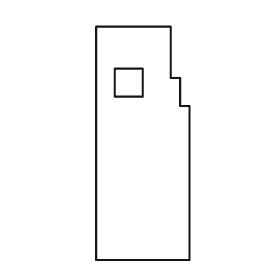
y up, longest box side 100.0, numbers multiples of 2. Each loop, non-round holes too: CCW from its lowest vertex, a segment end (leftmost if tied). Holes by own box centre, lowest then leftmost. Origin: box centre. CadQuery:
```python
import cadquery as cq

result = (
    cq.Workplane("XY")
    .moveTo(-20.0, -50.0)
    .lineTo(20.0, -50.0)
    .lineTo(20.0, 16.0)
    .lineTo(16.0, 16.0)
    .lineTo(16.0, 28.0)
    .lineTo(12.0, 28.0)
    .lineTo(12.0, 50.0)
    .lineTo(-20.0, 50.0)
    .close()
    .moveTo(-12.0, 20.0)
    .lineTo(0.0, 20.0)
    .lineTo(0.0, 32.0)
    .lineTo(-12.0, 32.0)
    .close()
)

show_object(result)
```